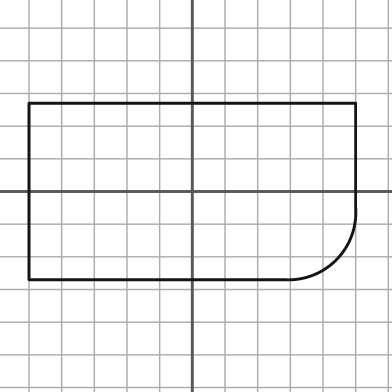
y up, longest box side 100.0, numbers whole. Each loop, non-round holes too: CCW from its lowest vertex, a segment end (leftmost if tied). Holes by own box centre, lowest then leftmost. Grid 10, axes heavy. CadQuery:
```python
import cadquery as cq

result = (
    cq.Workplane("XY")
    .moveTo(-50.0, -27.0)
    .lineTo(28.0, -27.0)
    .threePointArc((44.0, -21.0), (50.0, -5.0))
    .lineTo(50.0, 27.0)
    .lineTo(-50.0, 27.0)
    .close()
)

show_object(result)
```